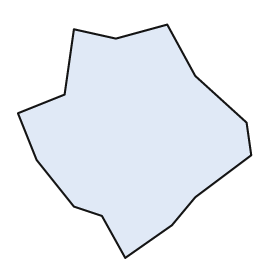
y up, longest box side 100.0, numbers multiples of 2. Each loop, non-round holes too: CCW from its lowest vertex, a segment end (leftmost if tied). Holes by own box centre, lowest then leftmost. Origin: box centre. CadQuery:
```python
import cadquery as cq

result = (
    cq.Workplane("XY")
    .moveTo(-4.0, -50.0)
    .lineTo(16.0, -36.0)
    .lineTo(26.0, -24.0)
    .lineTo(50.0, -6.0)
    .lineTo(48.0, 8.0)
    .lineTo(26.0, 28.0)
    .lineTo(14.0, 50.0)
    .lineTo(-8.0, 44.0)
    .lineTo(-26.0, 48.0)
    .lineTo(-30.0, 20.0)
    .lineTo(-50.0, 12.0)
    .lineTo(-42.0, -8.0)
    .lineTo(-26.0, -28.0)
    .lineTo(-14.0, -32.0)
    .close()
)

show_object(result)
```